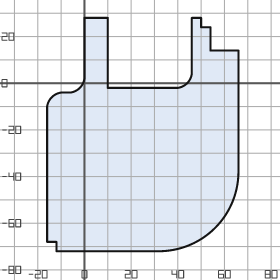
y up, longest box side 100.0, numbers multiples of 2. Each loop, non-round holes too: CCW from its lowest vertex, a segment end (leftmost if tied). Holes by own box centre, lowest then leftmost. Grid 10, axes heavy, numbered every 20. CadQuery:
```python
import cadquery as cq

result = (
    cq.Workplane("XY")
    .moveTo(-12.0, -72.0)
    .lineTo(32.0, -72.0)
    .threePointArc((56.0, -62.0), (66.0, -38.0))
    .lineTo(66.0, 14.0)
    .lineTo(54.0, 14.0)
    .lineTo(54.0, 24.0)
    .lineTo(50.0, 24.0)
    .lineTo(50.0, 28.0)
    .lineTo(46.0, 28.0)
    .lineTo(46.0, 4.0)
    .threePointArc((44.0, 0.0), (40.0, -2.0))
    .lineTo(10.0, -2.0)
    .lineTo(10.0, 28.0)
    .lineTo(0.0, 28.0)
    .lineTo(0.0, 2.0)
    .threePointArc((-2.0, -2.0), (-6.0, -4.0))
    .lineTo(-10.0, -4.0)
    .threePointArc((-14.0, -6.0), (-16.0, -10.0))
    .lineTo(-16.0, -68.0)
    .lineTo(-12.0, -68.0)
    .close()
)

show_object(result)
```